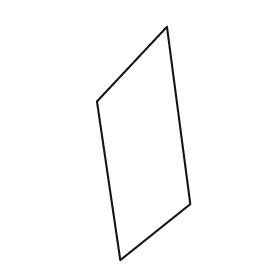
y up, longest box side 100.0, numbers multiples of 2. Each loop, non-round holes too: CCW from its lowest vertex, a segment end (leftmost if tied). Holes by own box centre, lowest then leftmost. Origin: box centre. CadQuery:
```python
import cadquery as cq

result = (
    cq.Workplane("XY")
    .moveTo(-10.0, -50.0)
    .lineTo(20.0, -26.0)
    .lineTo(10.0, 50.0)
    .lineTo(-20.0, 18.0)
    .close()
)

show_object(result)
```